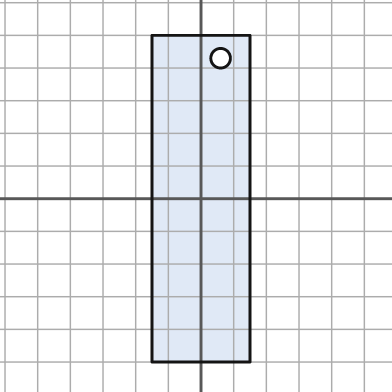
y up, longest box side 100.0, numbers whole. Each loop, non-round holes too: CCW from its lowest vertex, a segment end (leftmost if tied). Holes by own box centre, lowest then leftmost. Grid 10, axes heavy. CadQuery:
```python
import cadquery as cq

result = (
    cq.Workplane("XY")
    .moveTo(-15.0, -50.0)
    .lineTo(15.0, -50.0)
    .lineTo(15.0, 50.0)
    .lineTo(-15.0, 50.0)
    .close()
    .moveTo(6.0, 43.0)
    .circle(3.0)
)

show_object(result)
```